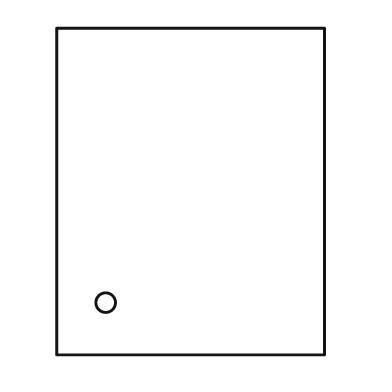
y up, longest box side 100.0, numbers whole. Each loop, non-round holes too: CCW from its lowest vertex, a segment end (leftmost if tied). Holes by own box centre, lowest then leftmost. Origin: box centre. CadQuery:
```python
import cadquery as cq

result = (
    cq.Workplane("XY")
    .moveTo(-41.0, -50.0)
    .lineTo(41.0, -50.0)
    .lineTo(41.0, 50.0)
    .lineTo(-41.0, 50.0)
    .close()
    .moveTo(-26.0, -34.0)
    .circle(3.0)
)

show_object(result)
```